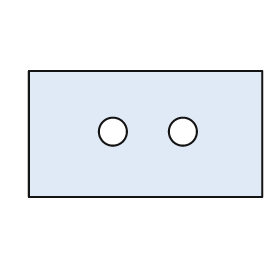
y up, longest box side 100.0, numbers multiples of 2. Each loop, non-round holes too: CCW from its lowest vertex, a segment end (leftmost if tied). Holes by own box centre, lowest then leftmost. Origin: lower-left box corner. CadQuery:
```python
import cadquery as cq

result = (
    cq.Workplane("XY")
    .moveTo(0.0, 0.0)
    .lineTo(100.0, 0.0)
    .lineTo(100.0, 54.0)
    .lineTo(0.0, 54.0)
    .close()
    .moveTo(36.0, 28.0)
    .circle(6.0)
    .moveTo(66.0, 28.0)
    .circle(6.0)
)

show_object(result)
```